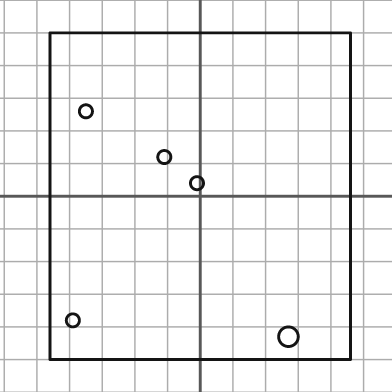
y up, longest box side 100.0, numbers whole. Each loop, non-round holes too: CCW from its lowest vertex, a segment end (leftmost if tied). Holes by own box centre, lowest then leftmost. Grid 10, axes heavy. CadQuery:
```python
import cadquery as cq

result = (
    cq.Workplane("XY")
    .moveTo(-46.0, -50.0)
    .lineTo(46.0, -50.0)
    .lineTo(46.0, 50.0)
    .lineTo(-46.0, 50.0)
    .close()
    .moveTo(27.0, -43.0)
    .circle(3.0)
    .moveTo(-39.0, -38.0)
    .circle(2.0)
    .moveTo(-1.0, 4.0)
    .circle(2.0)
    .moveTo(-11.0, 12.0)
    .circle(2.0)
    .moveTo(-35.0, 26.0)
    .circle(2.0)
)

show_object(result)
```